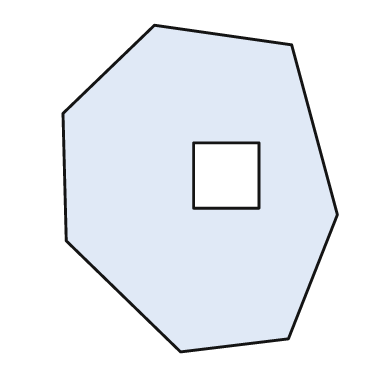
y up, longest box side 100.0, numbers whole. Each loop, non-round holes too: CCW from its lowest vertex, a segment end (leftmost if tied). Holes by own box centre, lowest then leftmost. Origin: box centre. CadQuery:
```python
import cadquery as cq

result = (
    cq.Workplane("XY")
    .moveTo(-6.0, -50.0)
    .lineTo(27.0, -46.0)
    .lineTo(42.0, -8.0)
    .lineTo(28.0, 44.0)
    .lineTo(-14.0, 50.0)
    .lineTo(-42.0, 23.0)
    .lineTo(-41.0, -16.0)
    .close()
    .moveTo(-2.0, -6.0)
    .lineTo(18.0, -6.0)
    .lineTo(18.0, 14.0)
    .lineTo(-2.0, 14.0)
    .close()
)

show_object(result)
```